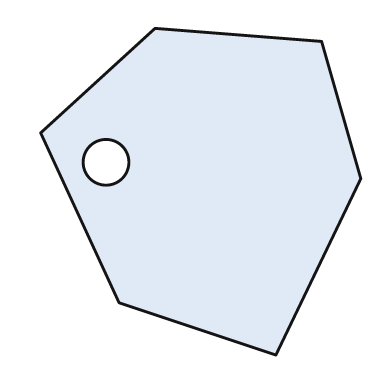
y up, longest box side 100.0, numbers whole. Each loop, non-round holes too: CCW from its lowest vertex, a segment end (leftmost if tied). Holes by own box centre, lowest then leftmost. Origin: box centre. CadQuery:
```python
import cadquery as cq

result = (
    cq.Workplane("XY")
    .moveTo(23.0, -50.0)
    .lineTo(49.0, 4.0)
    .lineTo(37.0, 46.0)
    .lineTo(-14.0, 50.0)
    .lineTo(-49.0, 18.0)
    .lineTo(-25.0, -34.0)
    .close()
    .moveTo(-29.0, 9.0)
    .circle(7.0)
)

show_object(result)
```